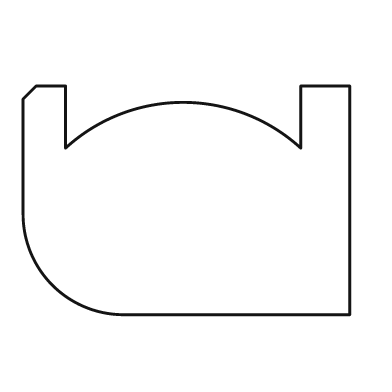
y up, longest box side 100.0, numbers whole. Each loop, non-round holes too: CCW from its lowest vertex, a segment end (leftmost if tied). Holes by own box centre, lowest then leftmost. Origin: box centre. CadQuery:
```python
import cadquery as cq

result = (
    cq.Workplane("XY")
    .moveTo(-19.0, -35.0)
    .lineTo(50.0, -35.0)
    .lineTo(50.0, 35.0)
    .lineTo(35.0, 35.0)
    .lineTo(35.0, 16.0)
    .threePointArc((-1.0, 30.0), (-37.0, 16.0))
    .lineTo(-37.0, 35.0)
    .lineTo(-46.0, 35.0)
    .lineTo(-50.0, 31.0)
    .lineTo(-50.0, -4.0)
    .threePointArc((-41.0, -26.0), (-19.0, -35.0))
    .close()
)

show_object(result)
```